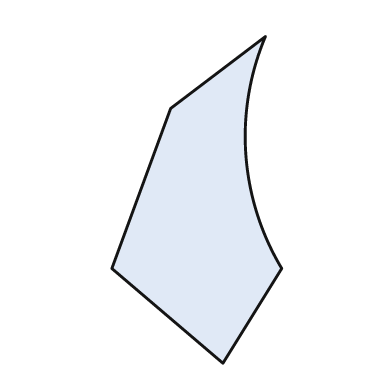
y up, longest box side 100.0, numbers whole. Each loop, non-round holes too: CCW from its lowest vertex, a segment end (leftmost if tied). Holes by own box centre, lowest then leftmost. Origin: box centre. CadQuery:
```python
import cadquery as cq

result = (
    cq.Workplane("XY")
    .moveTo(8.0, -50.0)
    .lineTo(26.0, -21.0)
    .threePointArc((15.0, 14.0), (21.0, 50.0))
    .lineTo(-8.0, 28.0)
    .lineTo(-26.0, -21.0)
    .close()
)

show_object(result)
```